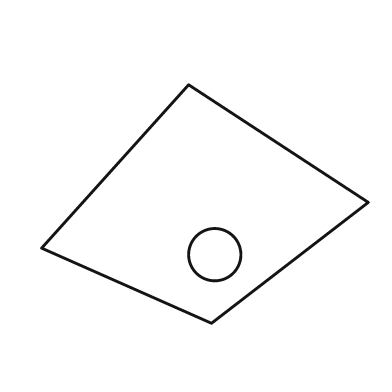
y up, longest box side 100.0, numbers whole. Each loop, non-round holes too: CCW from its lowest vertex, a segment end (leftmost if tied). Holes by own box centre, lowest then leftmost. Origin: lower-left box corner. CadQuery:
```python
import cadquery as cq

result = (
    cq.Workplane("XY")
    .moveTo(52.0, 0.0)
    .lineTo(100.0, 37.0)
    .lineTo(45.0, 73.0)
    .lineTo(0.0, 23.0)
    .close()
    .moveTo(53.0, 21.0)
    .circle(8.0)
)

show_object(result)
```